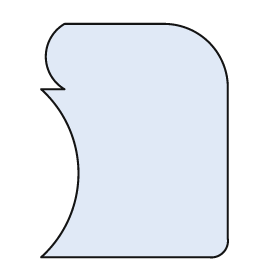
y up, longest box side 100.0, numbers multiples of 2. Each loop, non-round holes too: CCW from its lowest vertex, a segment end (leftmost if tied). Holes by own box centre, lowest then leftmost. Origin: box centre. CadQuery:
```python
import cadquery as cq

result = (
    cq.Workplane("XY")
    .moveTo(-40.0, -50.0)
    .lineTo(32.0, -50.0)
    .threePointArc((38.0, -48.0), (40.0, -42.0))
    .lineTo(40.0, 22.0)
    .threePointArc((32.0, 42.0), (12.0, 50.0))
    .lineTo(-30.0, 50.0)
    .threePointArc((-38.0, 36.0), (-30.0, 22.0))
    .lineTo(-40.0, 22.0)
    .threePointArc((-24.0, -14.0), (-40.0, -50.0))
    .close()
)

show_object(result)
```